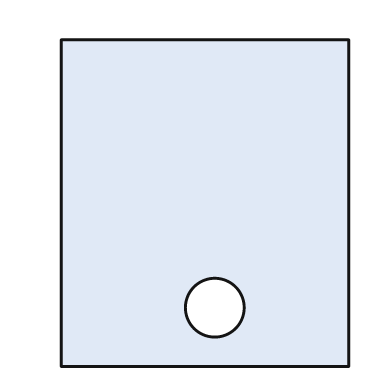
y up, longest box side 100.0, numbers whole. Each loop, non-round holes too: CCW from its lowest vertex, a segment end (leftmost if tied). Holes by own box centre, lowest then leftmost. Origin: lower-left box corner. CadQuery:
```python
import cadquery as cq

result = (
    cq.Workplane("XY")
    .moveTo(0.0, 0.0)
    .lineTo(88.0, 0.0)
    .lineTo(88.0, 100.0)
    .lineTo(0.0, 100.0)
    .close()
    .moveTo(47.0, 18.0)
    .circle(9.0)
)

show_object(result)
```